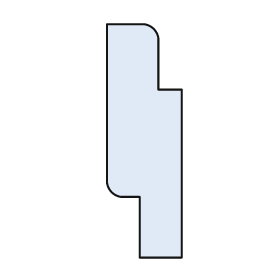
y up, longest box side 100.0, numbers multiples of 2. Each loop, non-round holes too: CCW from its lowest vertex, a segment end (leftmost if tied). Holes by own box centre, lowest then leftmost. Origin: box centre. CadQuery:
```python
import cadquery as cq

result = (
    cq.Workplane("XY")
    .moveTo(-2.0, -50.0)
    .lineTo(16.0, -50.0)
    .lineTo(16.0, 22.0)
    .lineTo(6.0, 22.0)
    .lineTo(6.0, 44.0)
    .threePointArc((4.0, 48.0), (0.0, 50.0))
    .lineTo(-16.0, 50.0)
    .lineTo(-16.0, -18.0)
    .threePointArc((-14.0, -22.0), (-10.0, -24.0))
    .lineTo(-2.0, -24.0)
    .close()
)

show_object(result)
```